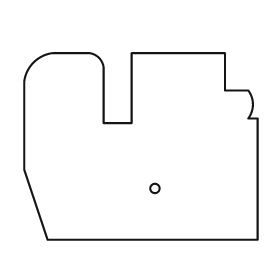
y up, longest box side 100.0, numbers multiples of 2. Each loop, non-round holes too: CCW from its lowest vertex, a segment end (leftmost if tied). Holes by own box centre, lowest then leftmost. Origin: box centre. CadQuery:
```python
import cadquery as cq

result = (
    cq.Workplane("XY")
    .moveTo(-40.0, -40.0)
    .lineTo(50.0, -40.0)
    .lineTo(50.0, 12.0)
    .lineTo(46.0, 12.0)
    .threePointArc((48.0, 18.0), (46.0, 24.0))
    .lineTo(36.0, 24.0)
    .lineTo(36.0, 40.0)
    .lineTo(-4.0, 40.0)
    .lineTo(-4.0, 10.0)
    .lineTo(-16.0, 10.0)
    .lineTo(-16.0, 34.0)
    .threePointArc((-18.0, 38.0), (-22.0, 40.0))
    .lineTo(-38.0, 40.0)
    .threePointArc((-46.0, 36.0), (-50.0, 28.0))
    .lineTo(-50.0, -10.0)
    .close()
    .moveTo(6.0, -18.0)
    .circle(2.0)
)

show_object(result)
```